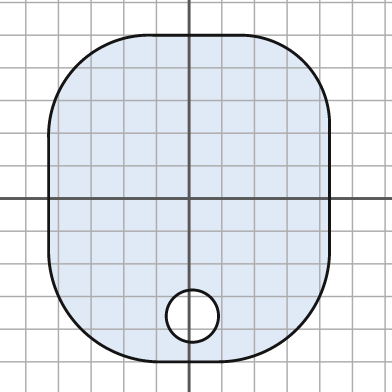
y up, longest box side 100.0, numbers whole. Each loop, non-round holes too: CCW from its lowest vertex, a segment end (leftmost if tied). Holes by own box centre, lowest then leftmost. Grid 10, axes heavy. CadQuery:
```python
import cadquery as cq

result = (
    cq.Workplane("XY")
    .moveTo(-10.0, -50.0)
    .lineTo(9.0, -50.0)
    .threePointArc((33.0, -40.0), (43.0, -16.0))
    .lineTo(43.0, 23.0)
    .threePointArc((35.0, 42.0), (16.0, 50.0))
    .lineTo(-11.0, 50.0)
    .threePointArc((-34.0, 41.0), (-43.0, 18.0))
    .lineTo(-43.0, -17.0)
    .threePointArc((-33.0, -40.0), (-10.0, -50.0))
    .close()
    .moveTo(1.0, -36.0)
    .circle(8.0)
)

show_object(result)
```